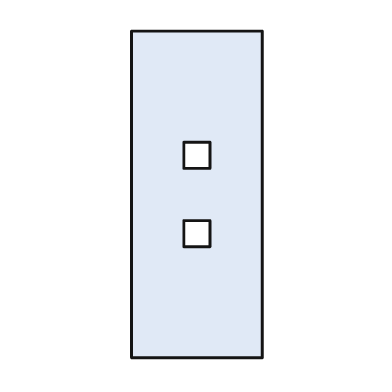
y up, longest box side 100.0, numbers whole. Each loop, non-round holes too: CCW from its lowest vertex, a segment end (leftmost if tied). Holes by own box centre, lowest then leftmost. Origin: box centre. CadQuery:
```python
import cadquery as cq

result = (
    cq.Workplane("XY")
    .moveTo(-20.0, -50.0)
    .lineTo(20.0, -50.0)
    .lineTo(20.0, 50.0)
    .lineTo(-20.0, 50.0)
    .close()
    .moveTo(-4.0, -16.0)
    .lineTo(4.0, -16.0)
    .lineTo(4.0, -8.0)
    .lineTo(-4.0, -8.0)
    .close()
    .moveTo(-4.0, 8.0)
    .lineTo(4.0, 8.0)
    .lineTo(4.0, 16.0)
    .lineTo(-4.0, 16.0)
    .close()
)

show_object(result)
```